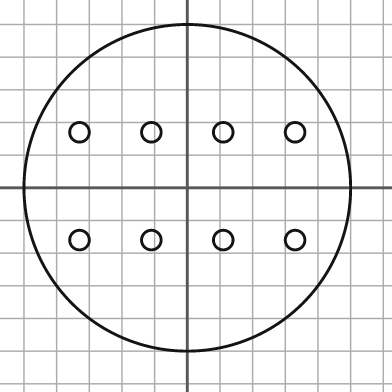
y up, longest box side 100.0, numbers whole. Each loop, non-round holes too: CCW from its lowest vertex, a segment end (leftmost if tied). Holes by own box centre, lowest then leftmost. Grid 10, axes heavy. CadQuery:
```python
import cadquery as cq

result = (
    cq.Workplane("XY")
    .moveTo(0.0, 0.0)
    .circle(50.0)
    .moveTo(-33.0, -16.0)
    .circle(3.0)
    .moveTo(-11.0, -16.0)
    .circle(3.0)
    .moveTo(11.0, -16.0)
    .circle(3.0)
    .moveTo(33.0, -16.0)
    .circle(3.0)
    .moveTo(-33.0, 17.0)
    .circle(3.0)
    .moveTo(-11.0, 17.0)
    .circle(3.0)
    .moveTo(11.0, 17.0)
    .circle(3.0)
    .moveTo(33.0, 17.0)
    .circle(3.0)
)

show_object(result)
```